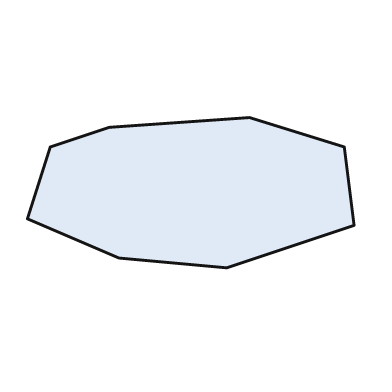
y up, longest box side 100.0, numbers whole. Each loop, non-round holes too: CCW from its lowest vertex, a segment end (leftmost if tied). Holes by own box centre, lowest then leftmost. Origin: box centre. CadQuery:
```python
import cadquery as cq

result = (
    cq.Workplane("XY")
    .moveTo(11.0, -23.0)
    .lineTo(50.0, -10.0)
    .lineTo(47.0, 14.0)
    .lineTo(18.0, 23.0)
    .lineTo(-25.0, 20.0)
    .lineTo(-43.0, 14.0)
    .lineTo(-50.0, -8.0)
    .lineTo(-22.0, -20.0)
    .close()
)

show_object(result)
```